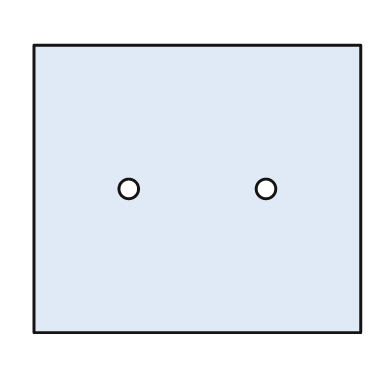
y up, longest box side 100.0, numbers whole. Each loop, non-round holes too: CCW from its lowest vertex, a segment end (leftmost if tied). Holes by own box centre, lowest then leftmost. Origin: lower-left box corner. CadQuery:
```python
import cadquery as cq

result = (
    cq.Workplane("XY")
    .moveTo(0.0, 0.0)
    .lineTo(100.0, 0.0)
    .lineTo(100.0, 88.0)
    .lineTo(0.0, 88.0)
    .close()
    .moveTo(29.0, 44.0)
    .circle(3.0)
    .moveTo(71.0, 44.0)
    .circle(3.0)
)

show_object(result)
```